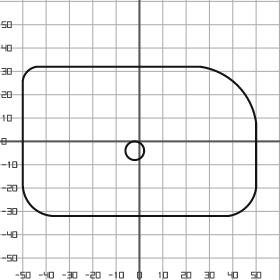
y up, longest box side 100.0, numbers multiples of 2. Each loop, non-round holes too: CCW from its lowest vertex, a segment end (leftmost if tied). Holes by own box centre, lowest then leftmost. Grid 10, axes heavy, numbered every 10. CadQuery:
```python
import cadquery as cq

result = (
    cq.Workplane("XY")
    .moveTo(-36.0, -32.0)
    .lineTo(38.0, -32.0)
    .threePointArc((46.0, -28.0), (50.0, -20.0))
    .lineTo(50.0, 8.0)
    .threePointArc((42.0, 24.0), (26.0, 32.0))
    .lineTo(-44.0, 32.0)
    .threePointArc((-48.0, 30.0), (-50.0, 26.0))
    .lineTo(-50.0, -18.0)
    .threePointArc((-46.0, -28.0), (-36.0, -32.0))
    .close()
    .moveTo(-2.0, -4.0)
    .circle(4.0)
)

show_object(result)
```